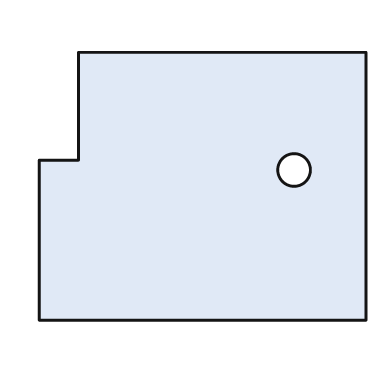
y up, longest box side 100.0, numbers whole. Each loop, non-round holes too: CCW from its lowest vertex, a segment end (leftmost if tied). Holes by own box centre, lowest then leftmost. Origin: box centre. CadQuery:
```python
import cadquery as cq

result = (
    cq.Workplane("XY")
    .moveTo(-50.0, -41.0)
    .lineTo(50.0, -41.0)
    .lineTo(50.0, 41.0)
    .lineTo(-38.0, 41.0)
    .lineTo(-38.0, 8.0)
    .lineTo(-50.0, 8.0)
    .close()
    .moveTo(28.0, 5.0)
    .circle(5.0)
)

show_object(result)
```